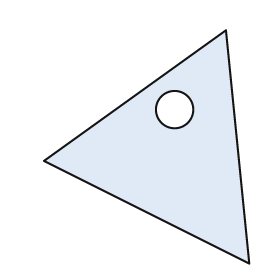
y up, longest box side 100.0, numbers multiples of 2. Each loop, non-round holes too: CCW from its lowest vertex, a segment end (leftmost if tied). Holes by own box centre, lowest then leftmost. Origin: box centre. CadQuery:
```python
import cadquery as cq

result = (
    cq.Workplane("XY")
    .moveTo(44.0, -50.0)
    .lineTo(34.0, 50.0)
    .lineTo(-44.0, -6.0)
    .close()
    .moveTo(12.0, 16.0)
    .circle(8.0)
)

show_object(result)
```